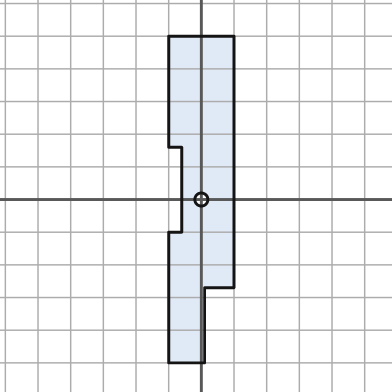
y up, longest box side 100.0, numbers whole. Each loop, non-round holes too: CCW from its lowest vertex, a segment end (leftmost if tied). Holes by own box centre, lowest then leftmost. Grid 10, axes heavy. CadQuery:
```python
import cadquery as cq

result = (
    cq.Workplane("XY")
    .moveTo(-10.0, -50.0)
    .lineTo(1.0, -50.0)
    .lineTo(1.0, -27.0)
    .lineTo(10.0, -27.0)
    .lineTo(10.0, 50.0)
    .lineTo(-10.0, 50.0)
    .lineTo(-10.0, 16.0)
    .lineTo(-6.0, 16.0)
    .lineTo(-6.0, -10.0)
    .lineTo(-10.0, -10.0)
    .close()
    .moveTo(0.0, 0.0)
    .circle(2.0)
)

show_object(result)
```